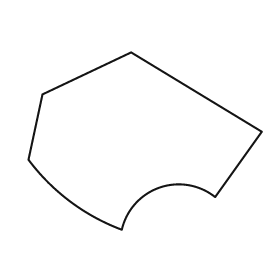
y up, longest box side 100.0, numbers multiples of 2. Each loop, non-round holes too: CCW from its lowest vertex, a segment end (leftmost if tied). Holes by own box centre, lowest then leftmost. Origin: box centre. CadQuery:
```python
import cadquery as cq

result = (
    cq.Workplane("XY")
    .moveTo(-10.0, -38.0)
    .threePointArc((6.0, -20.0), (30.0, -24.0))
    .lineTo(50.0, 4.0)
    .lineTo(-6.0, 38.0)
    .lineTo(-44.0, 20.0)
    .lineTo(-50.0, -8.0)
    .threePointArc((-32.0, -26.0), (-10.0, -38.0))
    .close()
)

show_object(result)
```